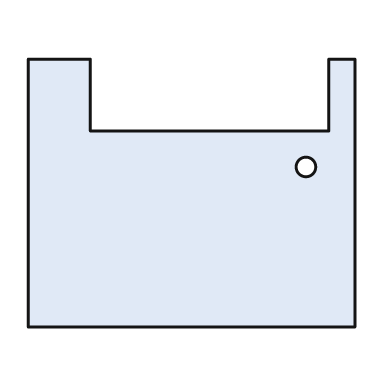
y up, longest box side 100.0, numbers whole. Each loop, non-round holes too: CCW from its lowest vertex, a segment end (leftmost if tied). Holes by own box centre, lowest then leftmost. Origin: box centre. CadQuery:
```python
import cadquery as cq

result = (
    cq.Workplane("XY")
    .moveTo(-50.0, -41.0)
    .lineTo(50.0, -41.0)
    .lineTo(50.0, 41.0)
    .lineTo(42.0, 41.0)
    .lineTo(42.0, 19.0)
    .lineTo(-31.0, 19.0)
    .lineTo(-31.0, 41.0)
    .lineTo(-50.0, 41.0)
    .close()
    .moveTo(35.0, 8.0)
    .circle(3.0)
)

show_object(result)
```